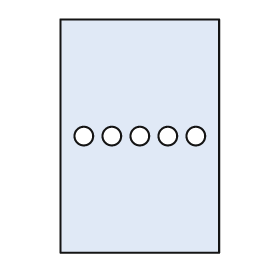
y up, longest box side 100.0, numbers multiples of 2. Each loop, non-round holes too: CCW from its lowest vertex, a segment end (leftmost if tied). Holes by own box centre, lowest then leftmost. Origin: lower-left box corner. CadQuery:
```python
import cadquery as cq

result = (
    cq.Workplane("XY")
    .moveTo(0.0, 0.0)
    .lineTo(68.0, 0.0)
    .lineTo(68.0, 100.0)
    .lineTo(0.0, 100.0)
    .close()
    .moveTo(10.0, 50.0)
    .circle(4.0)
    .moveTo(22.0, 50.0)
    .circle(4.0)
    .moveTo(34.0, 50.0)
    .circle(4.0)
    .moveTo(46.0, 50.0)
    .circle(4.0)
    .moveTo(58.0, 50.0)
    .circle(4.0)
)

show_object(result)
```